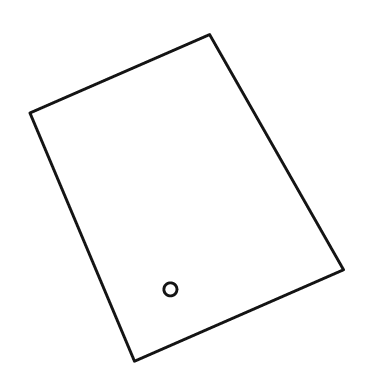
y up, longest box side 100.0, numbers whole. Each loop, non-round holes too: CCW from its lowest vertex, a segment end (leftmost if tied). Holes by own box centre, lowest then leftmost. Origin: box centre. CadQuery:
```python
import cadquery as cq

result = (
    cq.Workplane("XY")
    .moveTo(-16.0, -50.0)
    .lineTo(48.0, -22.0)
    .lineTo(7.0, 50.0)
    .lineTo(-48.0, 26.0)
    .close()
    .moveTo(-5.0, -28.0)
    .circle(2.0)
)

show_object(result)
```